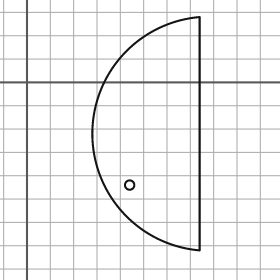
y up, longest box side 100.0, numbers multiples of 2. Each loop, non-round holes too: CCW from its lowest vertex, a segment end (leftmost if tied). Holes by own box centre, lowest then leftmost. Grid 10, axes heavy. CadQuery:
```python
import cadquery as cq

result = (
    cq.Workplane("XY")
    .moveTo(74.0, -72.0)
    .lineTo(74.0, 28.0)
    .threePointArc((28.0, -22.0), (74.0, -72.0))
    .close()
    .moveTo(44.0, -44.0)
    .circle(2.0)
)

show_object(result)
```